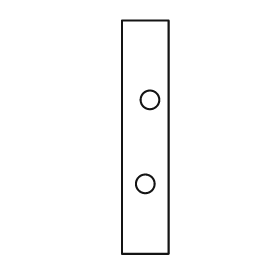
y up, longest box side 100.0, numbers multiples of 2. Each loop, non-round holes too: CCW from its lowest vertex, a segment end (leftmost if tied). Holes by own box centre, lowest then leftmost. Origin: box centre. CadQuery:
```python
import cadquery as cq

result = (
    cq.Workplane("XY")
    .moveTo(-10.0, -50.0)
    .lineTo(10.0, -50.0)
    .lineTo(10.0, 50.0)
    .lineTo(-10.0, 50.0)
    .close()
    .moveTo(0.0, -20.0)
    .circle(4.0)
    .moveTo(2.0, 16.0)
    .circle(4.0)
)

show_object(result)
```